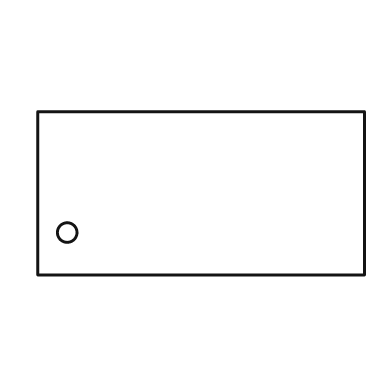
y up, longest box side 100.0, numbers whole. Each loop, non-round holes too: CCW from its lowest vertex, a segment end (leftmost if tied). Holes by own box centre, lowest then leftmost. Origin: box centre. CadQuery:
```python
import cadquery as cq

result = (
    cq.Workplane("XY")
    .moveTo(-50.0, -25.0)
    .lineTo(50.0, -25.0)
    .lineTo(50.0, 25.0)
    .lineTo(-50.0, 25.0)
    .close()
    .moveTo(-41.0, -12.0)
    .circle(3.0)
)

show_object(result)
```